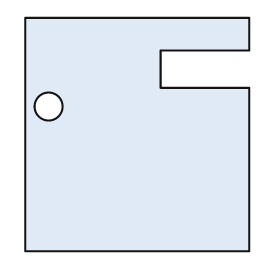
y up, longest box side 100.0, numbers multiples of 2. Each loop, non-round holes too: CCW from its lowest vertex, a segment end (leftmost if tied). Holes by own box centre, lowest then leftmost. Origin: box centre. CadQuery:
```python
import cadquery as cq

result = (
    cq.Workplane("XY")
    .moveTo(-48.0, -50.0)
    .lineTo(48.0, -50.0)
    .lineTo(48.0, 20.0)
    .lineTo(10.0, 20.0)
    .lineTo(10.0, 36.0)
    .lineTo(48.0, 36.0)
    .lineTo(48.0, 50.0)
    .lineTo(-48.0, 50.0)
    .close()
    .moveTo(-38.0, 12.0)
    .circle(6.0)
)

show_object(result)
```